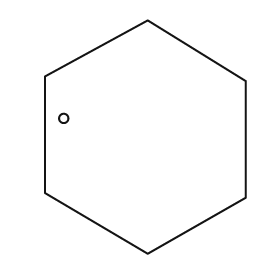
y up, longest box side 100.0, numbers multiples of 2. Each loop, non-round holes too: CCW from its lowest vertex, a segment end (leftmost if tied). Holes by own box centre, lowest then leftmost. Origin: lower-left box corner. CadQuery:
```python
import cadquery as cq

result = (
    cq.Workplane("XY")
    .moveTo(44.0, 0.0)
    .lineTo(86.0, 24.0)
    .lineTo(86.0, 74.0)
    .lineTo(44.0, 100.0)
    .lineTo(0.0, 76.0)
    .lineTo(0.0, 26.0)
    .close()
    .moveTo(8.0, 58.0)
    .circle(2.0)
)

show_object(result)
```